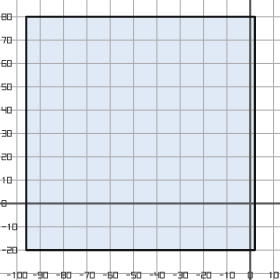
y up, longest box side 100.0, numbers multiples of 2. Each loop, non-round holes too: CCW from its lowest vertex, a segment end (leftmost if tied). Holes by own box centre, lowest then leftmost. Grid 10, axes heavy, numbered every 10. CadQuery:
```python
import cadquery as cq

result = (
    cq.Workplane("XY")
    .moveTo(-96.0, -20.0)
    .lineTo(2.0, -20.0)
    .lineTo(2.0, 80.0)
    .lineTo(-96.0, 80.0)
    .close()
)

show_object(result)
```